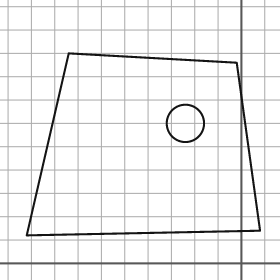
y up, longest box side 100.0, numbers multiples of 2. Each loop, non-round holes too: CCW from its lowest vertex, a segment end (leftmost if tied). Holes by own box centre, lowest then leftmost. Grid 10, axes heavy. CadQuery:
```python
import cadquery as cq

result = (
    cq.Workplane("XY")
    .moveTo(-92.0, 12.0)
    .lineTo(8.0, 14.0)
    .lineTo(-2.0, 86.0)
    .lineTo(-74.0, 90.0)
    .close()
    .moveTo(-24.0, 60.0)
    .circle(8.0)
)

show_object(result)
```